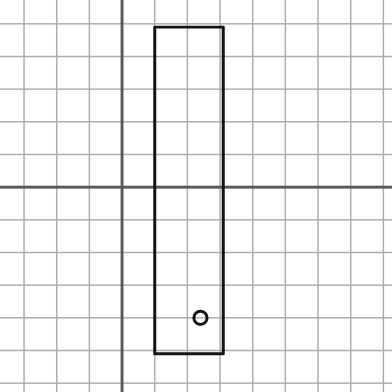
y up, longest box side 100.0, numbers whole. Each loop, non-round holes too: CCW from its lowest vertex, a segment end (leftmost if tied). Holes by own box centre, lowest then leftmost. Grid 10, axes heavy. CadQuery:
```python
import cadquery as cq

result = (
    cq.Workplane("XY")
    .moveTo(10.0, -51.0)
    .lineTo(31.0, -51.0)
    .lineTo(31.0, 49.0)
    .lineTo(10.0, 49.0)
    .close()
    .moveTo(24.0, -40.0)
    .circle(2.0)
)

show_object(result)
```